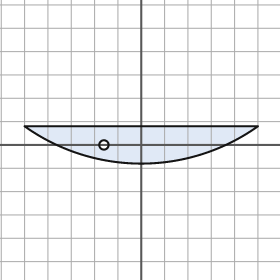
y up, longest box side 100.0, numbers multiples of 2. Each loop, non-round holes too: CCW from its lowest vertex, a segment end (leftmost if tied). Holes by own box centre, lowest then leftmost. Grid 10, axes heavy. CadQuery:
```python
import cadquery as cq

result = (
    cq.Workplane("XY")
    .moveTo(-50.0, 8.0)
    .threePointArc((0.0, -8.0), (50.0, 8.0))
    .close()
    .moveTo(-16.0, 0.0)
    .circle(2.0)
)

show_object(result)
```